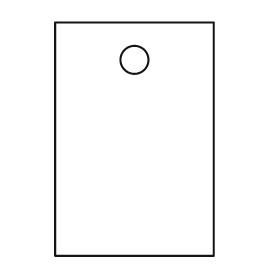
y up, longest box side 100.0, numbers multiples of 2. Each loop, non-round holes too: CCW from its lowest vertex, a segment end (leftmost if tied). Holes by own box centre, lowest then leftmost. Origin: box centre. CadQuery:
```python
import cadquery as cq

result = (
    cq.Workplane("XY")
    .moveTo(-34.0, -50.0)
    .lineTo(34.0, -50.0)
    .lineTo(34.0, 50.0)
    .lineTo(-34.0, 50.0)
    .close()
    .moveTo(0.0, 34.0)
    .circle(6.0)
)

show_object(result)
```